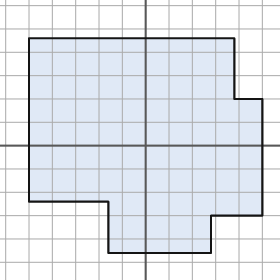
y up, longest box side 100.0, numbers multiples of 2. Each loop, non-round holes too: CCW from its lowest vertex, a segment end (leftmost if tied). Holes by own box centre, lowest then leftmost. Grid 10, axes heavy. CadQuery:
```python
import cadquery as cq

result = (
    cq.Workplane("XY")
    .moveTo(-16.0, -46.0)
    .lineTo(28.0, -46.0)
    .lineTo(28.0, -30.0)
    .lineTo(50.0, -30.0)
    .lineTo(50.0, 20.0)
    .lineTo(38.0, 20.0)
    .lineTo(38.0, 46.0)
    .lineTo(-50.0, 46.0)
    .lineTo(-50.0, -24.0)
    .lineTo(-16.0, -24.0)
    .close()
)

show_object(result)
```